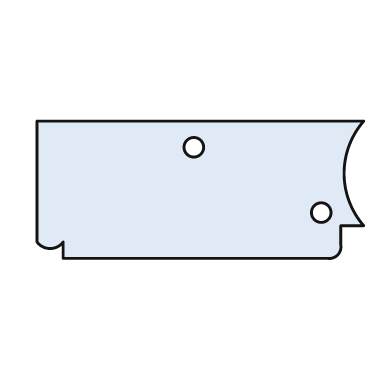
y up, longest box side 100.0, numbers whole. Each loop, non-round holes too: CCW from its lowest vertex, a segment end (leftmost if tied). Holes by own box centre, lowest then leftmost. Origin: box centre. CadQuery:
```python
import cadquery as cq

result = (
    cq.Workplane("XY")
    .moveTo(-42.0, -21.0)
    .lineTo(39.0, -21.0)
    .threePointArc((42.0, -20.0), (43.0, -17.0))
    .lineTo(43.0, -11.0)
    .lineTo(50.0, -11.0)
    .threePointArc((44.0, 5.0), (50.0, 21.0))
    .lineTo(-50.0, 21.0)
    .lineTo(-50.0, -16.0)
    .threePointArc((-46.0, -18.0), (-42.0, -16.0))
    .close()
    .moveTo(37.0, -7.0)
    .circle(3.0)
    .moveTo(-2.0, 13.0)
    .circle(3.0)
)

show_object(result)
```